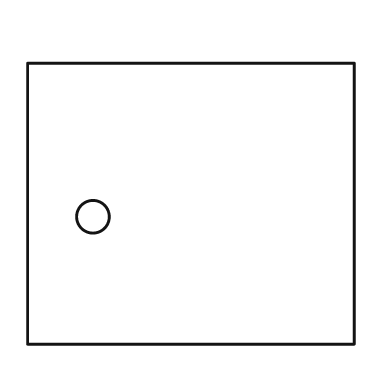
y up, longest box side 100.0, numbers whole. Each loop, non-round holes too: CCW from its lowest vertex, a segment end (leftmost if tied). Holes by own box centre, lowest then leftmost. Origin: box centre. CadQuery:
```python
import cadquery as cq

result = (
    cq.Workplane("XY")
    .moveTo(-50.0, -43.0)
    .lineTo(50.0, -43.0)
    .lineTo(50.0, 43.0)
    .lineTo(-50.0, 43.0)
    .close()
    .moveTo(-30.0, -4.0)
    .circle(5.0)
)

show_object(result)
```